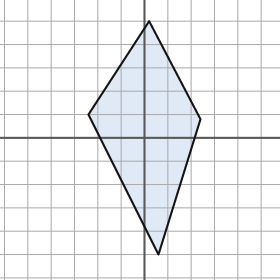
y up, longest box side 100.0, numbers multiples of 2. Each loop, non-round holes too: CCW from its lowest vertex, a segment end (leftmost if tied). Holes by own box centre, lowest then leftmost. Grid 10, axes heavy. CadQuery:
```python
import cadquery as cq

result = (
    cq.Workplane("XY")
    .moveTo(6.0, -50.0)
    .lineTo(24.0, 8.0)
    .lineTo(2.0, 50.0)
    .lineTo(-24.0, 10.0)
    .close()
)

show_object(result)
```